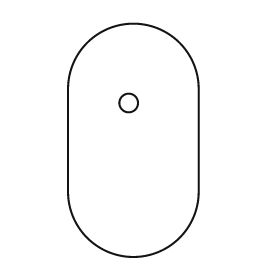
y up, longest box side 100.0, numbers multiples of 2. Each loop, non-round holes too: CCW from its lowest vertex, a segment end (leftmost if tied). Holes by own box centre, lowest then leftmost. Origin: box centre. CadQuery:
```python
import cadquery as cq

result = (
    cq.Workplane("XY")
    .moveTo(-28.0, -22.0)
    .threePointArc((0.0, -50.0), (28.0, -22.0))
    .lineTo(28.0, 22.0)
    .threePointArc((0.0, 50.0), (-28.0, 22.0))
    .close()
    .moveTo(-2.0, 16.0)
    .circle(4.0)
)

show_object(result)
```